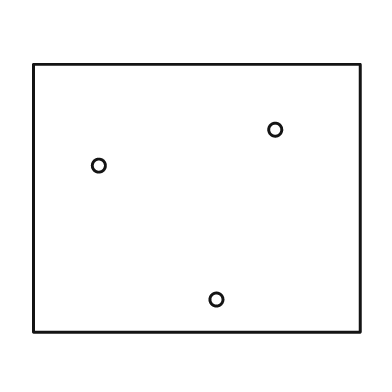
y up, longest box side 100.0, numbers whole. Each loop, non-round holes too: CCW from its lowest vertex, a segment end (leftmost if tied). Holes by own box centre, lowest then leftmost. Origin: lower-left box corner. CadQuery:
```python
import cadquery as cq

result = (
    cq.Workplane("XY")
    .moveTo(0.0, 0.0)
    .lineTo(100.0, 0.0)
    .lineTo(100.0, 82.0)
    .lineTo(0.0, 82.0)
    .close()
    .moveTo(56.0, 10.0)
    .circle(2.0)
    .moveTo(20.0, 51.0)
    .circle(2.0)
    .moveTo(74.0, 62.0)
    .circle(2.0)
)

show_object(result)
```